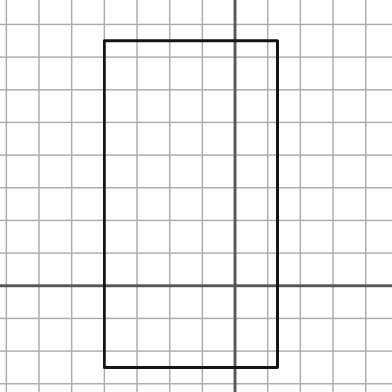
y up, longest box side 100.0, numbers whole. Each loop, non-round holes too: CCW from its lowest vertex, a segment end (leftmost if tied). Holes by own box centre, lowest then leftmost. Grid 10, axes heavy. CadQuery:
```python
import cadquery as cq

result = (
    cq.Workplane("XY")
    .moveTo(-40.0, -25.0)
    .lineTo(13.0, -25.0)
    .lineTo(13.0, 75.0)
    .lineTo(-40.0, 75.0)
    .close()
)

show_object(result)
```